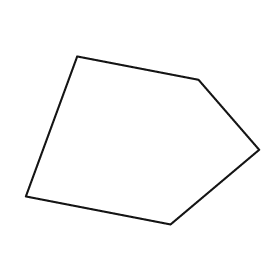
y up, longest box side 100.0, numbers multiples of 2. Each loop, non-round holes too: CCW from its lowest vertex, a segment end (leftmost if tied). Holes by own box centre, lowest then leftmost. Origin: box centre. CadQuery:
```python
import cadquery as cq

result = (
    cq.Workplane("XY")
    .moveTo(12.0, -36.0)
    .lineTo(50.0, -4.0)
    .lineTo(24.0, 26.0)
    .lineTo(-28.0, 36.0)
    .lineTo(-50.0, -24.0)
    .close()
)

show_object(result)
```